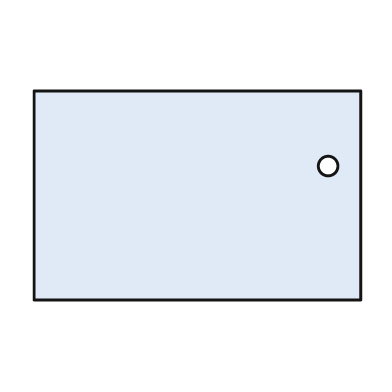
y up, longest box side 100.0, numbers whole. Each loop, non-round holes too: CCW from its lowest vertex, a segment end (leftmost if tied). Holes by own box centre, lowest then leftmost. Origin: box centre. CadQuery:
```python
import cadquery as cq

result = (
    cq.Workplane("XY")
    .moveTo(-50.0, -32.0)
    .lineTo(50.0, -32.0)
    .lineTo(50.0, 32.0)
    .lineTo(-50.0, 32.0)
    .close()
    .moveTo(40.0, 9.0)
    .circle(3.0)
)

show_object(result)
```